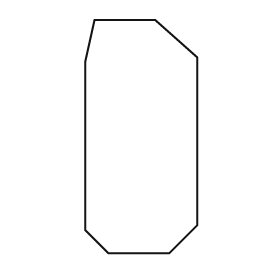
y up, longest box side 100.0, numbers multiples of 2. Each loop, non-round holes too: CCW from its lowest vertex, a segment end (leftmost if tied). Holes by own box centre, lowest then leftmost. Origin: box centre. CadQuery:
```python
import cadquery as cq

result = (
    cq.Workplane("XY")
    .moveTo(-14.0, -50.0)
    .lineTo(12.0, -50.0)
    .lineTo(24.0, -38.0)
    .lineTo(24.0, 34.0)
    .lineTo(6.0, 50.0)
    .lineTo(-20.0, 50.0)
    .lineTo(-24.0, 32.0)
    .lineTo(-24.0, -40.0)
    .close()
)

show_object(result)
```